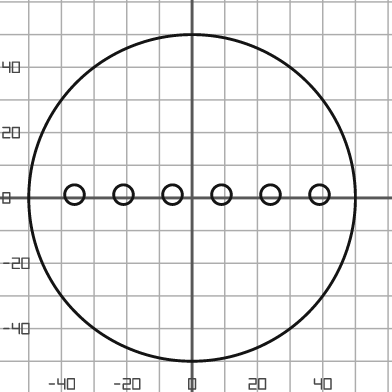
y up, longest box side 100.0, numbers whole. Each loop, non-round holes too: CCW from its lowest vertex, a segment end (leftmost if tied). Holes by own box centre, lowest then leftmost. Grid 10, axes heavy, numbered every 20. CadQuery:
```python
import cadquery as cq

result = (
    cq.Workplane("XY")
    .moveTo(0.0, 0.0)
    .circle(50.0)
    .moveTo(-36.0, 1.0)
    .circle(3.0)
    .moveTo(-21.0, 1.0)
    .circle(3.0)
    .moveTo(-6.0, 1.0)
    .circle(3.0)
    .moveTo(9.0, 1.0)
    .circle(3.0)
    .moveTo(24.0, 1.0)
    .circle(3.0)
    .moveTo(39.0, 1.0)
    .circle(3.0)
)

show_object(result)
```